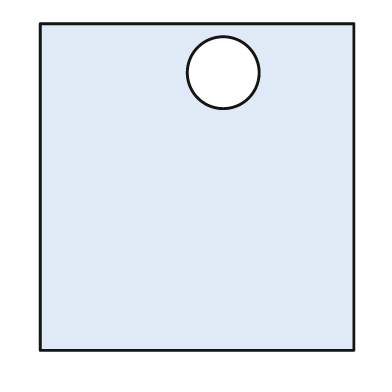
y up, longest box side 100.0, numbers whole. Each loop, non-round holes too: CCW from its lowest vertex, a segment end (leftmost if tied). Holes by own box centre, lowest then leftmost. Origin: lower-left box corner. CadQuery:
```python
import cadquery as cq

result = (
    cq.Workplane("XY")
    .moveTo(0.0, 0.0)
    .lineTo(96.0, 0.0)
    .lineTo(96.0, 100.0)
    .lineTo(0.0, 100.0)
    .close()
    .moveTo(56.0, 85.0)
    .circle(11.0)
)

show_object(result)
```